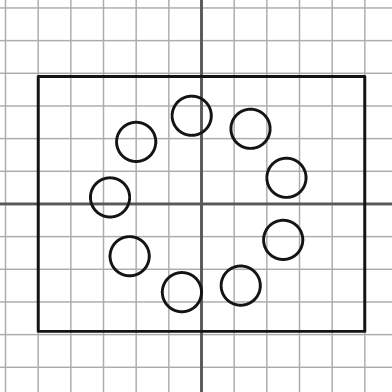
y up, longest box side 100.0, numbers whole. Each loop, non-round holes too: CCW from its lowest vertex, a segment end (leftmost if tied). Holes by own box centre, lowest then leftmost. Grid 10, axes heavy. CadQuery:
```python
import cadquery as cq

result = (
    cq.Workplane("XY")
    .moveTo(-50.0, -39.0)
    .lineTo(50.0, -39.0)
    .lineTo(50.0, 39.0)
    .lineTo(-50.0, 39.0)
    .close()
    .moveTo(-6.0, -27.0)
    .circle(6.0)
    .moveTo(12.0, -25.0)
    .circle(6.0)
    .moveTo(-22.0, -16.0)
    .circle(6.0)
    .moveTo(25.0, -11.0)
    .circle(6.0)
    .moveTo(-28.0, 2.0)
    .circle(6.0)
    .moveTo(26.0, 8.0)
    .circle(6.0)
    .moveTo(-20.0, 19.0)
    .circle(6.0)
    .moveTo(15.0, 23.0)
    .circle(6.0)
    .moveTo(-3.0, 27.0)
    .circle(6.0)
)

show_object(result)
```